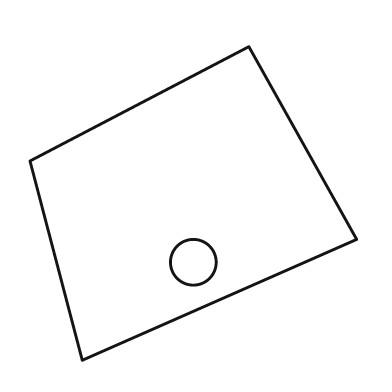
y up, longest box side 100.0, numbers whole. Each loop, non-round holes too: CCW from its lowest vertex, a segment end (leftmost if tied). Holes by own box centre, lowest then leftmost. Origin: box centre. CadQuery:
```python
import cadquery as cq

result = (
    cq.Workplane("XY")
    .moveTo(-34.0, -48.0)
    .lineTo(50.0, -11.0)
    .lineTo(17.0, 48.0)
    .lineTo(-50.0, 13.0)
    .close()
    .moveTo(0.0, -18.0)
    .circle(7.0)
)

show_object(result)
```